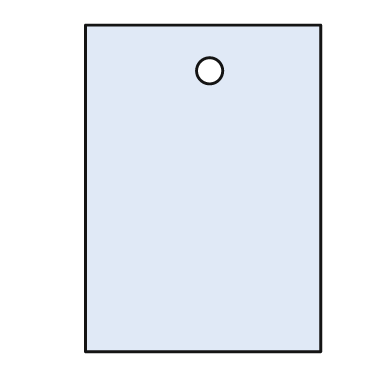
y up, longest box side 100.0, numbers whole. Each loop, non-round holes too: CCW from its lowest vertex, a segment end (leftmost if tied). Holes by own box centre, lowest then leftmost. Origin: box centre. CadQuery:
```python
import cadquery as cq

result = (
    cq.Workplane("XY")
    .moveTo(-36.0, -50.0)
    .lineTo(36.0, -50.0)
    .lineTo(36.0, 50.0)
    .lineTo(-36.0, 50.0)
    .close()
    .moveTo(2.0, 36.0)
    .circle(4.0)
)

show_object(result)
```